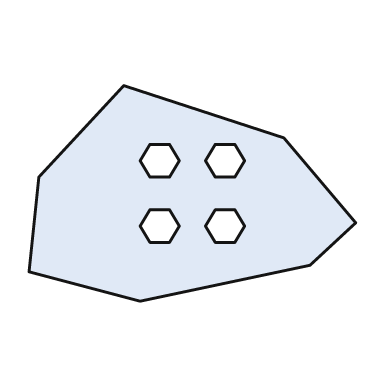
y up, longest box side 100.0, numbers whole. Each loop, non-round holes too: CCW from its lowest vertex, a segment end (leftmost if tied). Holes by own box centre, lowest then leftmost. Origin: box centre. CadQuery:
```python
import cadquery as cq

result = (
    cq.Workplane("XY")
    .moveTo(-16.0, -33.0)
    .lineTo(36.0, -22.0)
    .lineTo(50.0, -9.0)
    .lineTo(28.0, 17.0)
    .lineTo(-21.0, 33.0)
    .lineTo(-47.0, 5.0)
    .lineTo(-50.0, -24.0)
    .close()
    .moveTo(-13.0, -15.0)
    .lineTo(-7.0, -15.0)
    .lineTo(-4.0, -10.0)
    .lineTo(-7.0, -5.0)
    .lineTo(-13.0, -5.0)
    .lineTo(-16.0, -10.0)
    .close()
    .moveTo(7.0, -15.0)
    .lineTo(13.0, -15.0)
    .lineTo(16.0, -10.0)
    .lineTo(13.0, -5.0)
    .lineTo(7.0, -5.0)
    .lineTo(4.0, -10.0)
    .close()
    .moveTo(-13.0, 5.0)
    .lineTo(-7.0, 5.0)
    .lineTo(-4.0, 10.0)
    .lineTo(-7.0, 15.0)
    .lineTo(-13.0, 15.0)
    .lineTo(-16.0, 10.0)
    .close()
    .moveTo(7.0, 5.0)
    .lineTo(13.0, 5.0)
    .lineTo(16.0, 10.0)
    .lineTo(13.0, 15.0)
    .lineTo(7.0, 15.0)
    .lineTo(4.0, 10.0)
    .close()
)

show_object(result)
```